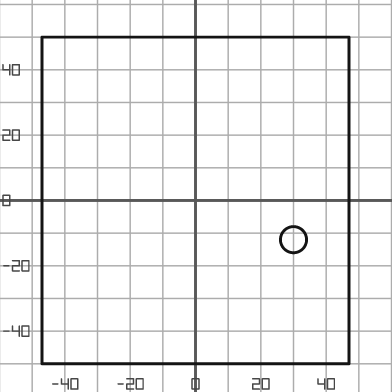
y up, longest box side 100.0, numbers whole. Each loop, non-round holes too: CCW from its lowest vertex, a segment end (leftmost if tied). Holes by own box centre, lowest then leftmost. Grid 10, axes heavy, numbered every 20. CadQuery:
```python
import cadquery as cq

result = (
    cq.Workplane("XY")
    .moveTo(-47.0, -50.0)
    .lineTo(47.0, -50.0)
    .lineTo(47.0, 50.0)
    .lineTo(-47.0, 50.0)
    .close()
    .moveTo(30.0, -12.0)
    .circle(4.0)
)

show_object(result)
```